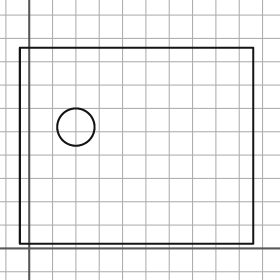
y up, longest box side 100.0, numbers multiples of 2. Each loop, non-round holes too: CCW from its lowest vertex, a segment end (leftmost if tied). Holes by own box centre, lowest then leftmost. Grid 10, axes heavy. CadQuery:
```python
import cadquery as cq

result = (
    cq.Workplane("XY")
    .moveTo(-4.0, 2.0)
    .lineTo(96.0, 2.0)
    .lineTo(96.0, 86.0)
    .lineTo(-4.0, 86.0)
    .close()
    .moveTo(20.0, 52.0)
    .circle(8.0)
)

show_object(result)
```